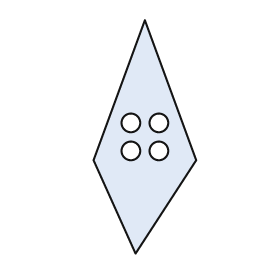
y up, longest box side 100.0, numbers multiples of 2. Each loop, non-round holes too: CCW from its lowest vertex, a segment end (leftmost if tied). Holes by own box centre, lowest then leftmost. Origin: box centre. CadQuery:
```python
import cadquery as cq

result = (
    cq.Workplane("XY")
    .moveTo(-4.0, -50.0)
    .lineTo(22.0, -10.0)
    .lineTo(0.0, 50.0)
    .lineTo(-22.0, -10.0)
    .close()
    .moveTo(-6.0, -6.0)
    .circle(4.0)
    .moveTo(6.0, -6.0)
    .circle(4.0)
    .moveTo(-6.0, 6.0)
    .circle(4.0)
    .moveTo(6.0, 6.0)
    .circle(4.0)
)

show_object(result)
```